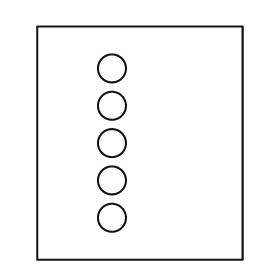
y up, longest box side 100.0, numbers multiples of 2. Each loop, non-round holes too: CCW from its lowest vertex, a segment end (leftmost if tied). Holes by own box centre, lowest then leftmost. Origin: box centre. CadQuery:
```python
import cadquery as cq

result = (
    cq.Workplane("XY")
    .moveTo(-44.0, -50.0)
    .lineTo(44.0, -50.0)
    .lineTo(44.0, 50.0)
    .lineTo(-44.0, 50.0)
    .close()
    .moveTo(-12.0, -32.0)
    .circle(6.0)
    .moveTo(-12.0, -16.0)
    .circle(6.0)
    .moveTo(-12.0, 0.0)
    .circle(6.0)
    .moveTo(-12.0, 16.0)
    .circle(6.0)
    .moveTo(-12.0, 32.0)
    .circle(6.0)
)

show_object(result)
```